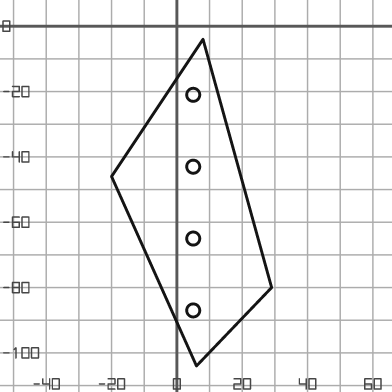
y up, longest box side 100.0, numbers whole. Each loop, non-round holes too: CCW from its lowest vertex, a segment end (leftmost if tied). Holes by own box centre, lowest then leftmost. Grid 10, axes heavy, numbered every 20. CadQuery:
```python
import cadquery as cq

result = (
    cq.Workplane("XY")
    .moveTo(6.0, -104.0)
    .lineTo(29.0, -80.0)
    .lineTo(8.0, -4.0)
    .lineTo(-20.0, -46.0)
    .close()
    .moveTo(5.0, -87.0)
    .circle(2.0)
    .moveTo(5.0, -65.0)
    .circle(2.0)
    .moveTo(5.0, -43.0)
    .circle(2.0)
    .moveTo(5.0, -21.0)
    .circle(2.0)
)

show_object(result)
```